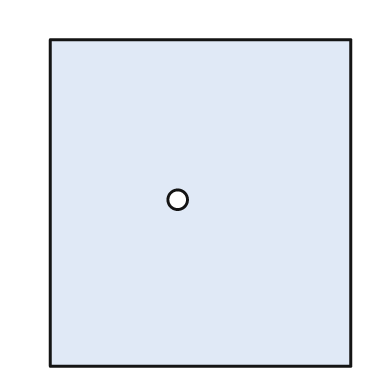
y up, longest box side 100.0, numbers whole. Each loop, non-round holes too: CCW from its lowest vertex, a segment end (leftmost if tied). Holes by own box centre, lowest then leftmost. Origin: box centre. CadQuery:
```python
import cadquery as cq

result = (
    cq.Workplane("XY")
    .moveTo(-46.0, -50.0)
    .lineTo(46.0, -50.0)
    .lineTo(46.0, 50.0)
    .lineTo(-46.0, 50.0)
    .close()
    .moveTo(-7.0, 1.0)
    .circle(3.0)
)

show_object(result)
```